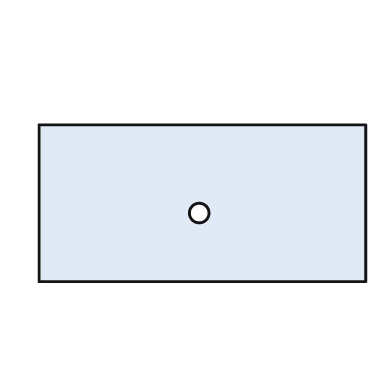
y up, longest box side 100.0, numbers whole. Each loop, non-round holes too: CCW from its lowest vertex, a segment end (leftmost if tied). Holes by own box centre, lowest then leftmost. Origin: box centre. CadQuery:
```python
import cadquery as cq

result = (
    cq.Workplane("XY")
    .moveTo(-50.0, -24.0)
    .lineTo(50.0, -24.0)
    .lineTo(50.0, 24.0)
    .lineTo(-50.0, 24.0)
    .close()
    .moveTo(-1.0, -3.0)
    .circle(3.0)
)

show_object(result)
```